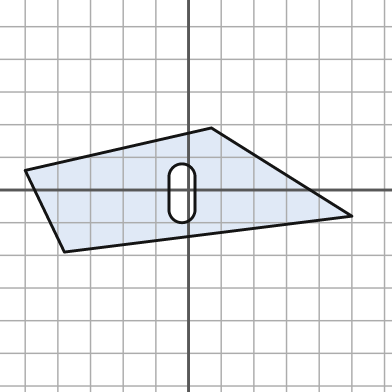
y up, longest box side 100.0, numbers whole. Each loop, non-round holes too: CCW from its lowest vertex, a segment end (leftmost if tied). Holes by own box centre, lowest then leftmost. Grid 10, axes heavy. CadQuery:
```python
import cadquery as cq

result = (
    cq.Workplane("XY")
    .moveTo(-38.0, -19.0)
    .lineTo(50.0, -8.0)
    .lineTo(7.0, 19.0)
    .lineTo(-50.0, 6.0)
    .close()
    .moveTo(-6.0, -6.0)
    .threePointArc((-2.0, -10.0), (2.0, -6.0))
    .lineTo(2.0, 4.0)
    .threePointArc((-2.0, 8.0), (-6.0, 4.0))
    .close()
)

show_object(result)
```